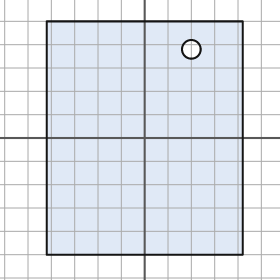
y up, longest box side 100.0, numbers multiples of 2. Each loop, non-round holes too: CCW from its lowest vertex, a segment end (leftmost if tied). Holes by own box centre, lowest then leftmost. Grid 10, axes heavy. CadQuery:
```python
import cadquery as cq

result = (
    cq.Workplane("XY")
    .moveTo(-42.0, -50.0)
    .lineTo(42.0, -50.0)
    .lineTo(42.0, 50.0)
    .lineTo(-42.0, 50.0)
    .close()
    .moveTo(20.0, 38.0)
    .circle(4.0)
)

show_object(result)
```